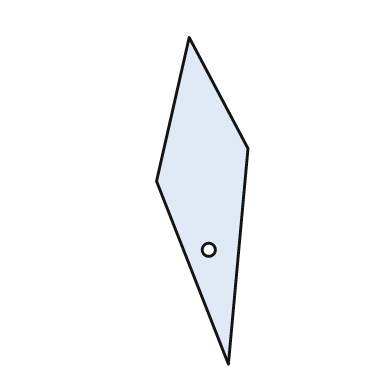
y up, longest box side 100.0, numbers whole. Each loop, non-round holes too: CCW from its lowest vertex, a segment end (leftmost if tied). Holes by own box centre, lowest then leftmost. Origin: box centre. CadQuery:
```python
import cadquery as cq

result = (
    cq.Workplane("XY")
    .moveTo(8.0, -50.0)
    .lineTo(14.0, 16.0)
    .lineTo(-4.0, 50.0)
    .lineTo(-14.0, 6.0)
    .close()
    .moveTo(2.0, -15.0)
    .circle(2.0)
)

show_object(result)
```